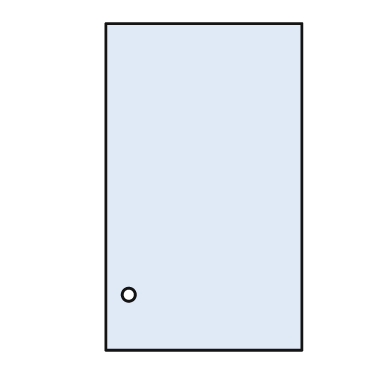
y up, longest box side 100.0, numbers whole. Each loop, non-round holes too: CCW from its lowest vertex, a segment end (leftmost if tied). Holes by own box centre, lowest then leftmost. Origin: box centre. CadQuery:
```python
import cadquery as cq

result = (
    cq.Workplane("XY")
    .moveTo(-30.0, -50.0)
    .lineTo(30.0, -50.0)
    .lineTo(30.0, 50.0)
    .lineTo(-30.0, 50.0)
    .close()
    .moveTo(-23.0, -33.0)
    .circle(2.0)
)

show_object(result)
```